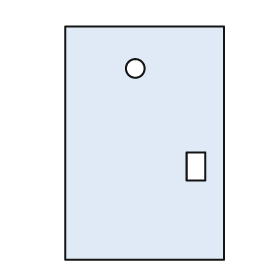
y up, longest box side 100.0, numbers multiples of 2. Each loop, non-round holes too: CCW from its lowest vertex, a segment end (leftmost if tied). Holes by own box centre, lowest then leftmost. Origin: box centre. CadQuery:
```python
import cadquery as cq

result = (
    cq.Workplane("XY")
    .moveTo(-34.0, -50.0)
    .lineTo(34.0, -50.0)
    .lineTo(34.0, 50.0)
    .lineTo(-34.0, 50.0)
    .close()
    .moveTo(18.0, -16.0)
    .lineTo(26.0, -16.0)
    .lineTo(26.0, -4.0)
    .lineTo(18.0, -4.0)
    .close()
    .moveTo(-4.0, 32.0)
    .circle(4.0)
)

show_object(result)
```